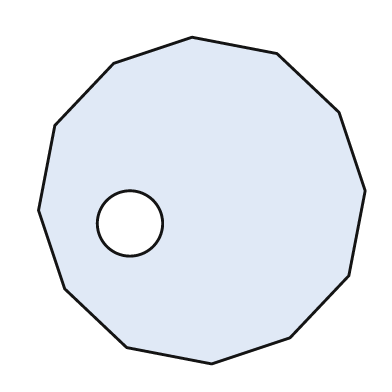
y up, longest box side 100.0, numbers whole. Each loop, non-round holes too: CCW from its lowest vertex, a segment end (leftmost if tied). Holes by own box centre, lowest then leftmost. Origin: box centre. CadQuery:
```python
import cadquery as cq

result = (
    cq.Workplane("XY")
    .moveTo(3.0, -50.0)
    .lineTo(27.0, -42.0)
    .lineTo(45.0, -23.0)
    .lineTo(50.0, 3.0)
    .lineTo(42.0, 27.0)
    .lineTo(23.0, 45.0)
    .lineTo(-3.0, 50.0)
    .lineTo(-27.0, 42.0)
    .lineTo(-45.0, 23.0)
    .lineTo(-50.0, -3.0)
    .lineTo(-42.0, -27.0)
    .lineTo(-23.0, -45.0)
    .close()
    .moveTo(-22.0, -7.0)
    .circle(10.0)
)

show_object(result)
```